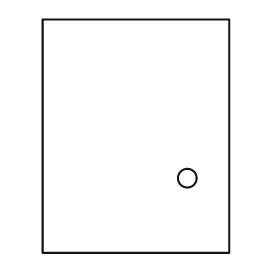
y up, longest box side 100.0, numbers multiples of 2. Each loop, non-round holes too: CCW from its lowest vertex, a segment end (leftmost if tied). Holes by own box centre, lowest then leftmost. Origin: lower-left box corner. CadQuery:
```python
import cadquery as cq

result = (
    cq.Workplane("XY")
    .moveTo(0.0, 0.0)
    .lineTo(80.0, 0.0)
    .lineTo(80.0, 100.0)
    .lineTo(0.0, 100.0)
    .close()
    .moveTo(62.0, 32.0)
    .circle(4.0)
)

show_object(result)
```